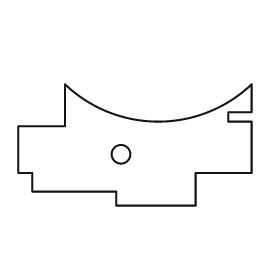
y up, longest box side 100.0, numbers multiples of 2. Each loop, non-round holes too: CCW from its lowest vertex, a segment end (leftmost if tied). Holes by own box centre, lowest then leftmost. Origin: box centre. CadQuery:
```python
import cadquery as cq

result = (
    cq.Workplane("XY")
    .moveTo(-8.0, -26.0)
    .lineTo(26.0, -26.0)
    .lineTo(26.0, -12.0)
    .lineTo(50.0, -12.0)
    .lineTo(50.0, 10.0)
    .lineTo(40.0, 10.0)
    .lineTo(40.0, 14.0)
    .lineTo(50.0, 14.0)
    .lineTo(50.0, 26.0)
    .threePointArc((10.0, 10.0), (-30.0, 26.0))
    .lineTo(-30.0, 8.0)
    .lineTo(-50.0, 8.0)
    .lineTo(-50.0, -12.0)
    .lineTo(-44.0, -12.0)
    .lineTo(-44.0, -20.0)
    .lineTo(-8.0, -20.0)
    .close()
    .moveTo(-6.0, -4.0)
    .circle(4.0)
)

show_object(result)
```